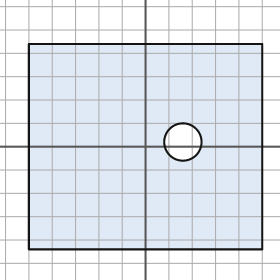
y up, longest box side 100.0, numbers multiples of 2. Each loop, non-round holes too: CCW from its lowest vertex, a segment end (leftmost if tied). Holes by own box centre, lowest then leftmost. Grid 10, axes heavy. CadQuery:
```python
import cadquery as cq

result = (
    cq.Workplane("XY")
    .moveTo(-50.0, -44.0)
    .lineTo(50.0, -44.0)
    .lineTo(50.0, 44.0)
    .lineTo(-50.0, 44.0)
    .close()
    .moveTo(16.0, 2.0)
    .circle(8.0)
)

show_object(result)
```